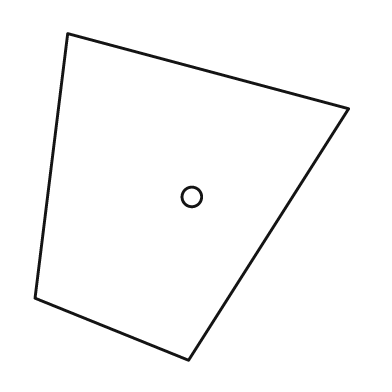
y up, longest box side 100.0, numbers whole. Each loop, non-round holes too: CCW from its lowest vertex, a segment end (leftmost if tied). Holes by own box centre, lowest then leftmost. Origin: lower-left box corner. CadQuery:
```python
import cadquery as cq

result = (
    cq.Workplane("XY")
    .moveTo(47.0, 0.0)
    .lineTo(96.0, 77.0)
    .lineTo(10.0, 100.0)
    .lineTo(0.0, 19.0)
    .close()
    .moveTo(48.0, 50.0)
    .circle(3.0)
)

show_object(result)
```